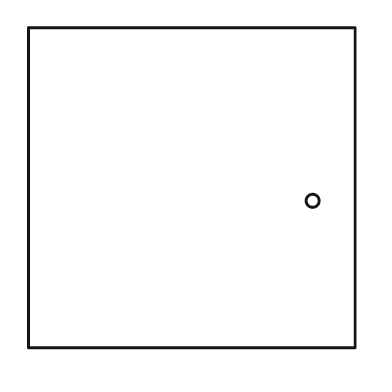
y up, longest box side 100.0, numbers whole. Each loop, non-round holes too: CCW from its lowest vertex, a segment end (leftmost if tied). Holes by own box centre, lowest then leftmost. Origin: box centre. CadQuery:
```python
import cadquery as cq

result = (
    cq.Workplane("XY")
    .moveTo(-50.0, -49.0)
    .lineTo(50.0, -49.0)
    .lineTo(50.0, 49.0)
    .lineTo(-50.0, 49.0)
    .close()
    .moveTo(37.0, -4.0)
    .circle(2.0)
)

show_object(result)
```